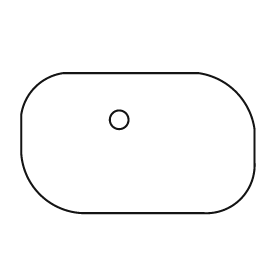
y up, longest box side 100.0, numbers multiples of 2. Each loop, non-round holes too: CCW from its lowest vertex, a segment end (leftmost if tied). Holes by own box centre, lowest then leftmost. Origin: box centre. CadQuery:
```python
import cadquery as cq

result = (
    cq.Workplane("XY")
    .moveTo(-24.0, -30.0)
    .lineTo(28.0, -30.0)
    .threePointArc((44.0, -24.0), (50.0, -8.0))
    .lineTo(50.0, 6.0)
    .threePointArc((42.0, 22.0), (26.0, 30.0))
    .lineTo(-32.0, 30.0)
    .threePointArc((-44.0, 24.0), (-50.0, 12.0))
    .lineTo(-50.0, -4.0)
    .threePointArc((-42.0, -22.0), (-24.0, -30.0))
    .close()
    .moveTo(-8.0, 10.0)
    .circle(4.0)
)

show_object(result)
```